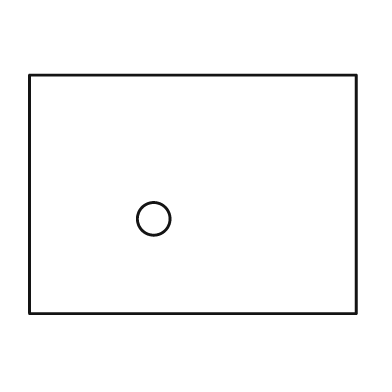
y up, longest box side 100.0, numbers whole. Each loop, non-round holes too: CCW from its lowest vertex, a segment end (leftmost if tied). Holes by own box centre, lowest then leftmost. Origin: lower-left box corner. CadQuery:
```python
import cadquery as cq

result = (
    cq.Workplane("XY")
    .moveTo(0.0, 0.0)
    .lineTo(100.0, 0.0)
    .lineTo(100.0, 73.0)
    .lineTo(0.0, 73.0)
    .close()
    .moveTo(38.0, 29.0)
    .circle(5.0)
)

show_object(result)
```